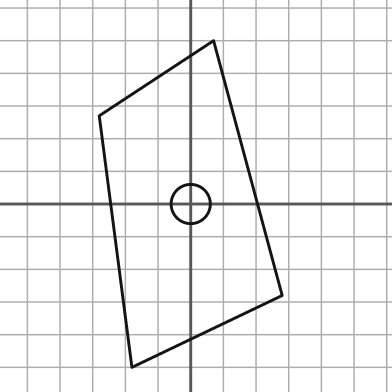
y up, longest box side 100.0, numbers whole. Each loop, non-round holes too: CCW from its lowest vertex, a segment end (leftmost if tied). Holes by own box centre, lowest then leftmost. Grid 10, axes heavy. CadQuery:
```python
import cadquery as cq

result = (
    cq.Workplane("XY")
    .moveTo(-18.0, -50.0)
    .lineTo(28.0, -28.0)
    .lineTo(7.0, 50.0)
    .lineTo(-28.0, 27.0)
    .close()
    .moveTo(0.0, 0.0)
    .circle(6.0)
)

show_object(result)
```